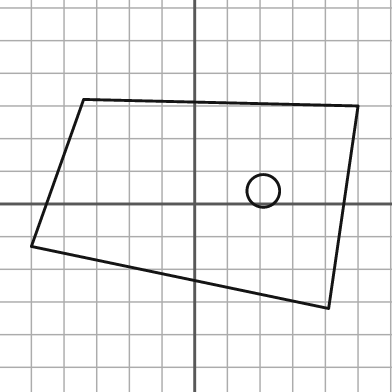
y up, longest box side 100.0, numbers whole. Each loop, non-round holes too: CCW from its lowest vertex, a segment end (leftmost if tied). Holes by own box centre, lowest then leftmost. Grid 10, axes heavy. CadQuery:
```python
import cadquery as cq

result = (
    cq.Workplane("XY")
    .moveTo(41.0, -32.0)
    .lineTo(50.0, 30.0)
    .lineTo(-34.0, 32.0)
    .lineTo(-50.0, -13.0)
    .close()
    .moveTo(21.0, 4.0)
    .circle(5.0)
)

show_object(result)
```